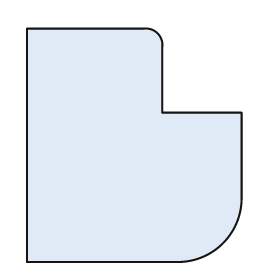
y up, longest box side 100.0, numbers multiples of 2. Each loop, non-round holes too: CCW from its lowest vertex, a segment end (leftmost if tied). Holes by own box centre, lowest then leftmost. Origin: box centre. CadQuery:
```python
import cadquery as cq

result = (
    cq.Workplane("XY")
    .moveTo(-46.0, -50.0)
    .lineTo(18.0, -50.0)
    .threePointArc((38.0, -42.0), (46.0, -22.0))
    .lineTo(46.0, 14.0)
    .lineTo(12.0, 14.0)
    .lineTo(12.0, 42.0)
    .threePointArc((10.0, 48.0), (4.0, 50.0))
    .lineTo(-46.0, 50.0)
    .close()
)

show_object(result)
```